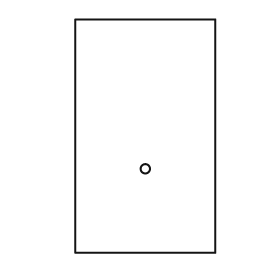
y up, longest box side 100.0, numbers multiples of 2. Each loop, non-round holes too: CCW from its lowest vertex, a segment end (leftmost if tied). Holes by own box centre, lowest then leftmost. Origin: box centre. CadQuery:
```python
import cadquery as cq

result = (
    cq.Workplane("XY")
    .moveTo(-30.0, -50.0)
    .lineTo(30.0, -50.0)
    .lineTo(30.0, 50.0)
    .lineTo(-30.0, 50.0)
    .close()
    .moveTo(0.0, -14.0)
    .circle(2.0)
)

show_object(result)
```